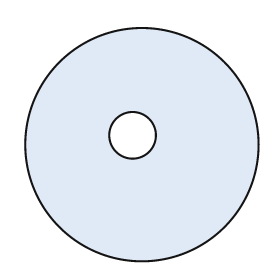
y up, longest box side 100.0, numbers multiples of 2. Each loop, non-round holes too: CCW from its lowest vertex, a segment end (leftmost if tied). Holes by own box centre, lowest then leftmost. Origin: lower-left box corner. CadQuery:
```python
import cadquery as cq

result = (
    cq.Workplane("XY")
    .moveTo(50.0, 50.0)
    .circle(50.0)
    .moveTo(46.0, 54.0)
    .circle(10.0)
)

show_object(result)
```